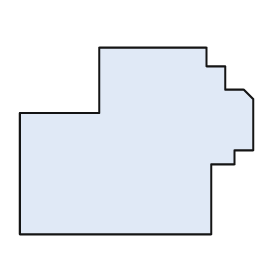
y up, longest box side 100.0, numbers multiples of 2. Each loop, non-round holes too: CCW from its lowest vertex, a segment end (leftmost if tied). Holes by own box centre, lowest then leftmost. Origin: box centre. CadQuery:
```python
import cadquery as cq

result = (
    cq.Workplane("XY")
    .moveTo(-50.0, -40.0)
    .lineTo(32.0, -40.0)
    .lineTo(32.0, -10.0)
    .lineTo(42.0, -10.0)
    .lineTo(42.0, -4.0)
    .lineTo(50.0, -4.0)
    .lineTo(50.0, 18.0)
    .lineTo(46.0, 22.0)
    .lineTo(38.0, 22.0)
    .lineTo(38.0, 32.0)
    .lineTo(30.0, 32.0)
    .lineTo(30.0, 40.0)
    .lineTo(-16.0, 40.0)
    .lineTo(-16.0, 12.0)
    .lineTo(-50.0, 12.0)
    .close()
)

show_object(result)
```